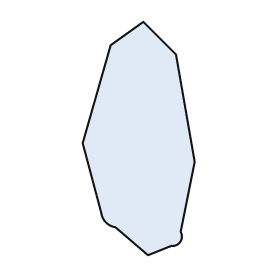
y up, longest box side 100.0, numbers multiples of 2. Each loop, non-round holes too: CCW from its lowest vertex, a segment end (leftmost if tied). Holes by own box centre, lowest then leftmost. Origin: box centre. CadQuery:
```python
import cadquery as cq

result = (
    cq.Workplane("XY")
    .moveTo(4.0, -50.0)
    .lineTo(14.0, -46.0)
    .threePointArc((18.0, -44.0), (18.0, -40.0))
    .lineTo(24.0, -10.0)
    .lineTo(16.0, 36.0)
    .lineTo(2.0, 50.0)
    .lineTo(-12.0, 40.0)
    .lineTo(-24.0, -2.0)
    .lineTo(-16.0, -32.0)
    .threePointArc((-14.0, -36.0), (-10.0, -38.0))
    .close()
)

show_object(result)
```